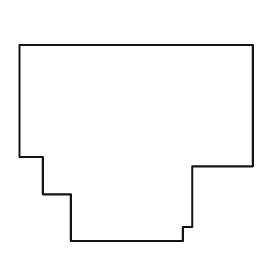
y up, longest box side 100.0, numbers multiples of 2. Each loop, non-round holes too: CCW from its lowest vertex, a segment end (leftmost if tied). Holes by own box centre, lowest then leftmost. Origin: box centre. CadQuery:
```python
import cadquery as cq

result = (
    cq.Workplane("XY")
    .moveTo(-28.0, -42.0)
    .lineTo(20.0, -42.0)
    .lineTo(20.0, -36.0)
    .lineTo(24.0, -36.0)
    .lineTo(24.0, -10.0)
    .lineTo(50.0, -10.0)
    .lineTo(50.0, 42.0)
    .lineTo(-50.0, 42.0)
    .lineTo(-50.0, -6.0)
    .lineTo(-40.0, -6.0)
    .lineTo(-40.0, -22.0)
    .lineTo(-28.0, -22.0)
    .close()
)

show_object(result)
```